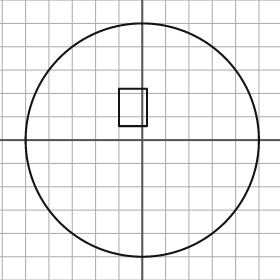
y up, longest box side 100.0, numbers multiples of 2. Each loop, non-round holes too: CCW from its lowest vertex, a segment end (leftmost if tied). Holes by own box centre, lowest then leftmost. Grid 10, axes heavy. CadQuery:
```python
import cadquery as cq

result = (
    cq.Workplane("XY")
    .moveTo(0.0, 0.0)
    .circle(50.0)
    .moveTo(-10.0, 6.0)
    .lineTo(2.0, 6.0)
    .lineTo(2.0, 22.0)
    .lineTo(-10.0, 22.0)
    .close()
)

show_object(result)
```